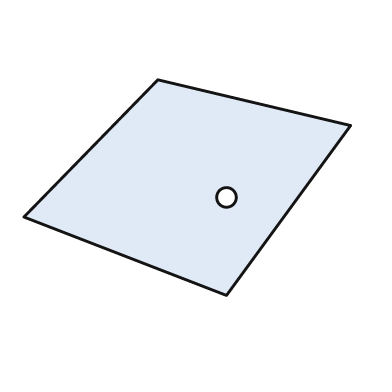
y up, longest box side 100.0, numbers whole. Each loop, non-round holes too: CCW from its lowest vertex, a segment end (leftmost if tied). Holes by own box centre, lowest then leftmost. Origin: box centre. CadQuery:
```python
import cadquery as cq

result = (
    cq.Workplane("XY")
    .moveTo(12.0, -33.0)
    .lineTo(50.0, 19.0)
    .lineTo(-9.0, 33.0)
    .lineTo(-50.0, -9.0)
    .close()
    .moveTo(12.0, -3.0)
    .circle(3.0)
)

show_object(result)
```